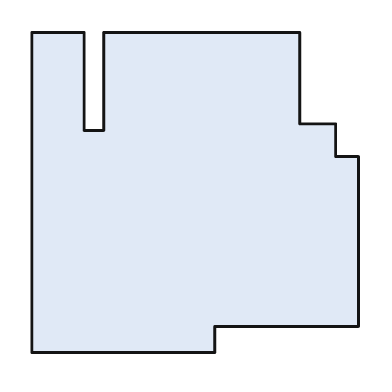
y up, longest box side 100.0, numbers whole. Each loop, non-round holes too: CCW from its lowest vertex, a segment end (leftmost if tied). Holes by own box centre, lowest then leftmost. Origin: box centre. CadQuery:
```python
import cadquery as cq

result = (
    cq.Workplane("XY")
    .moveTo(-50.0, -49.0)
    .lineTo(6.0, -49.0)
    .lineTo(6.0, -41.0)
    .lineTo(50.0, -41.0)
    .lineTo(50.0, 11.0)
    .lineTo(43.0, 11.0)
    .lineTo(43.0, 21.0)
    .lineTo(32.0, 21.0)
    .lineTo(32.0, 49.0)
    .lineTo(-28.0, 49.0)
    .lineTo(-28.0, 19.0)
    .lineTo(-34.0, 19.0)
    .lineTo(-34.0, 49.0)
    .lineTo(-50.0, 49.0)
    .close()
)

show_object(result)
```